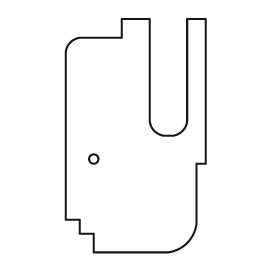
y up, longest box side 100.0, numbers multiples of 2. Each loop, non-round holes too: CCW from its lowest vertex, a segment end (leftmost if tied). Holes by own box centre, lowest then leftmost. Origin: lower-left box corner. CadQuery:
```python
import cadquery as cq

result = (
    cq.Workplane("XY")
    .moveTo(12.0, 0.0)
    .lineTo(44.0, 0.0)
    .threePointArc((52.0, 4.0), (56.0, 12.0))
    .lineTo(56.0, 38.0)
    .lineTo(60.0, 38.0)
    .lineTo(60.0, 100.0)
    .lineTo(52.0, 100.0)
    .lineTo(52.0, 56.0)
    .threePointArc((50.0, 52.0), (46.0, 50.0))
    .lineTo(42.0, 50.0)
    .threePointArc((38.0, 52.0), (36.0, 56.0))
    .lineTo(36.0, 100.0)
    .lineTo(24.0, 100.0)
    .lineTo(24.0, 92.0)
    .lineTo(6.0, 92.0)
    .threePointArc((2.0, 90.0), (0.0, 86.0))
    .lineTo(0.0, 14.0)
    .lineTo(6.0, 14.0)
    .lineTo(6.0, 8.0)
    .lineTo(12.0, 8.0)
    .close()
    .moveTo(12.0, 40.0)
    .circle(2.0)
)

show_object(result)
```